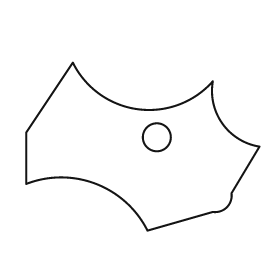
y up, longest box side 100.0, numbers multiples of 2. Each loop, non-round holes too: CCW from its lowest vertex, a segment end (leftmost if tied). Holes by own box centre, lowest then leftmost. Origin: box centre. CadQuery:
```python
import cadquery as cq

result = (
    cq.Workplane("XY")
    .moveTo(2.0, -36.0)
    .lineTo(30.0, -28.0)
    .threePointArc((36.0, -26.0), (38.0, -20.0))
    .lineTo(50.0, 0.0)
    .threePointArc((34.0, 10.0), (30.0, 28.0))
    .threePointArc((-2.0, 16.0), (-30.0, 36.0))
    .lineTo(-50.0, 6.0)
    .lineTo(-50.0, -16.0)
    .threePointArc((-20.0, -16.0), (2.0, -36.0))
    .close()
    .moveTo(6.0, 4.0)
    .circle(6.0)
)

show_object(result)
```